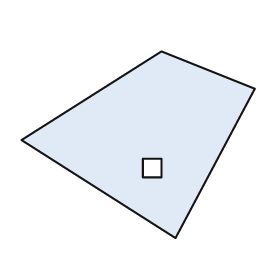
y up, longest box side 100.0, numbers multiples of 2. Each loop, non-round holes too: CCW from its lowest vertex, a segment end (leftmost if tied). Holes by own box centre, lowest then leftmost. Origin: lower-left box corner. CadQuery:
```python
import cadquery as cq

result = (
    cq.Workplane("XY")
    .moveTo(66.0, 0.0)
    .lineTo(100.0, 64.0)
    .lineTo(60.0, 80.0)
    .lineTo(0.0, 42.0)
    .close()
    .moveTo(52.0, 26.0)
    .lineTo(60.0, 26.0)
    .lineTo(60.0, 34.0)
    .lineTo(52.0, 34.0)
    .close()
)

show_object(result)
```